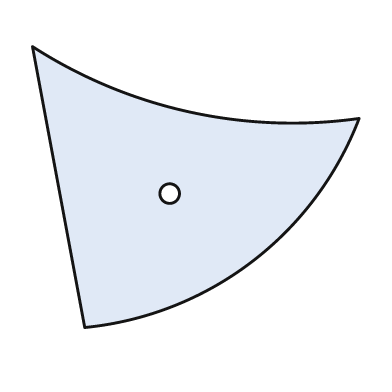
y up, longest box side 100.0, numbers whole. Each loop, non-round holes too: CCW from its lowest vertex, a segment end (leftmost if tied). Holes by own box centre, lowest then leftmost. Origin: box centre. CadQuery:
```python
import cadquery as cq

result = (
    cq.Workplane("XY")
    .moveTo(-34.0, -43.0)
    .threePointArc((17.0, -23.0), (50.0, 21.0))
    .threePointArc((-2.0, 23.0), (-50.0, 43.0))
    .close()
    .moveTo(-8.0, -2.0)
    .circle(3.0)
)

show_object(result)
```